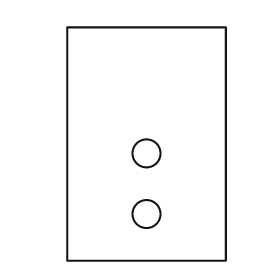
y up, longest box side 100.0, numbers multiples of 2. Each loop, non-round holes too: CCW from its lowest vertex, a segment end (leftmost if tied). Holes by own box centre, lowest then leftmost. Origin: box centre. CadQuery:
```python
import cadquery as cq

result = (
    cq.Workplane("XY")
    .moveTo(-34.0, -50.0)
    .lineTo(34.0, -50.0)
    .lineTo(34.0, 50.0)
    .lineTo(-34.0, 50.0)
    .close()
    .moveTo(0.0, -30.0)
    .circle(6.0)
    .moveTo(0.0, -4.0)
    .circle(6.0)
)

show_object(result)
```